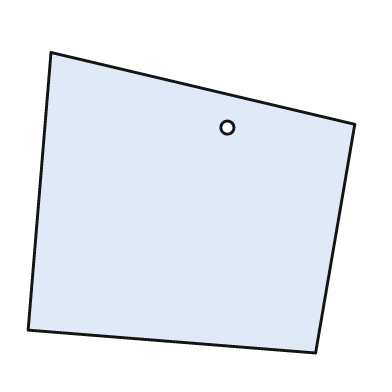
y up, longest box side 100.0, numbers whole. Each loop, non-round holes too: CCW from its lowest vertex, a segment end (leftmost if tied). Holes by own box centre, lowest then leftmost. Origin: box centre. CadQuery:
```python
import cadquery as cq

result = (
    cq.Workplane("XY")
    .moveTo(38.0, -46.0)
    .lineTo(50.0, 24.0)
    .lineTo(-43.0, 46.0)
    .lineTo(-50.0, -39.0)
    .close()
    .moveTo(11.0, 23.0)
    .circle(2.0)
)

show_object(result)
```